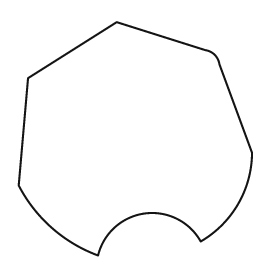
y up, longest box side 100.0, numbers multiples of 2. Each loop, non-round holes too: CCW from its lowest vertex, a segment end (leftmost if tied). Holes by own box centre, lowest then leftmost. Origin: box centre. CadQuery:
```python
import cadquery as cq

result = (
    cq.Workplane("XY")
    .moveTo(-16.0, -50.0)
    .threePointArc((4.0, -32.0), (28.0, -44.0))
    .threePointArc((44.0, -28.0), (50.0, -6.0))
    .lineTo(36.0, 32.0)
    .threePointArc((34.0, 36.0), (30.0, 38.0))
    .lineTo(-8.0, 50.0)
    .lineTo(-46.0, 26.0)
    .lineTo(-50.0, -20.0)
    .threePointArc((-36.0, -38.0), (-16.0, -50.0))
    .close()
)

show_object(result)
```